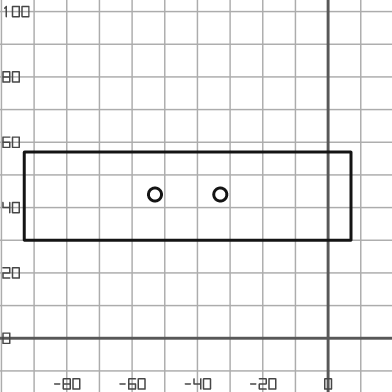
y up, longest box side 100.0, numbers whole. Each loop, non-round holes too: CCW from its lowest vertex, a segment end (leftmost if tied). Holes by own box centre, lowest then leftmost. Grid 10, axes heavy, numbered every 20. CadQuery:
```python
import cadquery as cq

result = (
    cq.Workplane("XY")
    .moveTo(-93.0, 30.0)
    .lineTo(7.0, 30.0)
    .lineTo(7.0, 57.0)
    .lineTo(-93.0, 57.0)
    .close()
    .moveTo(-53.0, 44.0)
    .circle(2.0)
    .moveTo(-33.0, 44.0)
    .circle(2.0)
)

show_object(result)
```